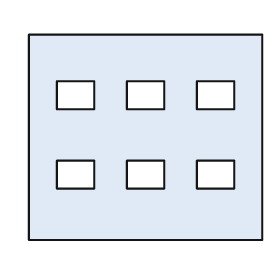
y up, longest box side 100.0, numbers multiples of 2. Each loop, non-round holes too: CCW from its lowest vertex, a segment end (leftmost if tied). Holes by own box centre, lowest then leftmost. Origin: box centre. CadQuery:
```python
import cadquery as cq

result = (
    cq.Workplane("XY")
    .moveTo(-50.0, -44.0)
    .lineTo(50.0, -44.0)
    .lineTo(50.0, 44.0)
    .lineTo(-50.0, 44.0)
    .close()
    .moveTo(-38.0, -22.0)
    .lineTo(-22.0, -22.0)
    .lineTo(-22.0, -10.0)
    .lineTo(-38.0, -10.0)
    .close()
    .moveTo(-8.0, -22.0)
    .lineTo(8.0, -22.0)
    .lineTo(8.0, -10.0)
    .lineTo(-8.0, -10.0)
    .close()
    .moveTo(22.0, -22.0)
    .lineTo(38.0, -22.0)
    .lineTo(38.0, -10.0)
    .lineTo(22.0, -10.0)
    .close()
    .moveTo(-38.0, 12.0)
    .lineTo(-22.0, 12.0)
    .lineTo(-22.0, 24.0)
    .lineTo(-38.0, 24.0)
    .close()
    .moveTo(-8.0, 12.0)
    .lineTo(8.0, 12.0)
    .lineTo(8.0, 24.0)
    .lineTo(-8.0, 24.0)
    .close()
    .moveTo(22.0, 12.0)
    .lineTo(38.0, 12.0)
    .lineTo(38.0, 24.0)
    .lineTo(22.0, 24.0)
    .close()
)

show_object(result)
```